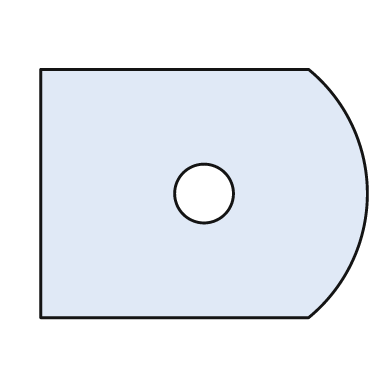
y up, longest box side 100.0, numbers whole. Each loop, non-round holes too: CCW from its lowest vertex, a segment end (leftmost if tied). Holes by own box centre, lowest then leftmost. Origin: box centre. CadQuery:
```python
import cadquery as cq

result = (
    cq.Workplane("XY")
    .moveTo(-50.0, -38.0)
    .lineTo(32.0, -38.0)
    .threePointArc((50.0, 0.0), (32.0, 38.0))
    .lineTo(-50.0, 38.0)
    .close()
    .moveTo(0.0, 0.0)
    .circle(9.0)
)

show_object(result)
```